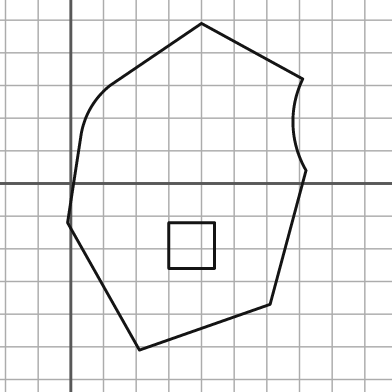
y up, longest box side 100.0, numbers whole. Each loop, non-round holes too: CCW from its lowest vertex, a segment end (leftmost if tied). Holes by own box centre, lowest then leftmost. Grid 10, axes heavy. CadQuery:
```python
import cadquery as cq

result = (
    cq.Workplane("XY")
    .moveTo(21.0, -51.0)
    .lineTo(61.0, -37.0)
    .lineTo(72.0, 4.0)
    .threePointArc((68.0, 18.0), (71.0, 32.0))
    .lineTo(40.0, 49.0)
    .lineTo(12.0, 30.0)
    .threePointArc((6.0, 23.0), (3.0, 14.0))
    .lineTo(-1.0, -12.0)
    .close()
    .moveTo(30.0, -26.0)
    .lineTo(44.0, -26.0)
    .lineTo(44.0, -12.0)
    .lineTo(30.0, -12.0)
    .close()
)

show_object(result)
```